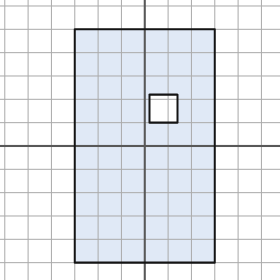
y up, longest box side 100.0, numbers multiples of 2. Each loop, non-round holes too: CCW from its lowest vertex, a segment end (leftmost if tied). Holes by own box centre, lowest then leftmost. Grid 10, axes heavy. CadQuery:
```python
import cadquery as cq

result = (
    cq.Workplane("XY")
    .moveTo(-30.0, -50.0)
    .lineTo(30.0, -50.0)
    .lineTo(30.0, 50.0)
    .lineTo(-30.0, 50.0)
    .close()
    .moveTo(2.0, 10.0)
    .lineTo(14.0, 10.0)
    .lineTo(14.0, 22.0)
    .lineTo(2.0, 22.0)
    .close()
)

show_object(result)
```